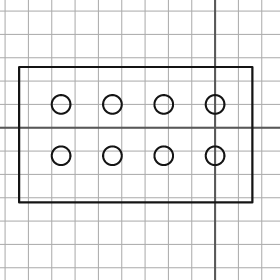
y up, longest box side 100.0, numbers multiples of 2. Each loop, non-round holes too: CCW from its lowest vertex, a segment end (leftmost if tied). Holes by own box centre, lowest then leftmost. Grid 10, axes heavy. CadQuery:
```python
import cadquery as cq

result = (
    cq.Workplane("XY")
    .moveTo(-84.0, -32.0)
    .lineTo(16.0, -32.0)
    .lineTo(16.0, 26.0)
    .lineTo(-84.0, 26.0)
    .close()
    .moveTo(-66.0, -12.0)
    .circle(4.0)
    .moveTo(-44.0, -12.0)
    .circle(4.0)
    .moveTo(-22.0, -12.0)
    .circle(4.0)
    .moveTo(0.0, -12.0)
    .circle(4.0)
    .moveTo(-66.0, 10.0)
    .circle(4.0)
    .moveTo(-44.0, 10.0)
    .circle(4.0)
    .moveTo(-22.0, 10.0)
    .circle(4.0)
    .moveTo(0.0, 10.0)
    .circle(4.0)
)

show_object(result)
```